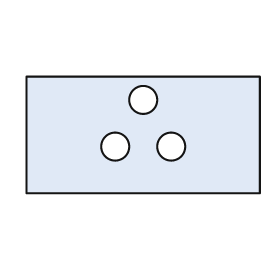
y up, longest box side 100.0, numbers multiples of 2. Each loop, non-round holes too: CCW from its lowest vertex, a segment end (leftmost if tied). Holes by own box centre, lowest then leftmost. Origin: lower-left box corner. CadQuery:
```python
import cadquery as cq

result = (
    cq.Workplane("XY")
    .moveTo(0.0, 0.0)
    .lineTo(100.0, 0.0)
    .lineTo(100.0, 50.0)
    .lineTo(0.0, 50.0)
    .close()
    .moveTo(38.0, 20.0)
    .circle(6.0)
    .moveTo(62.0, 20.0)
    .circle(6.0)
    .moveTo(50.0, 40.0)
    .circle(6.0)
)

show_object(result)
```